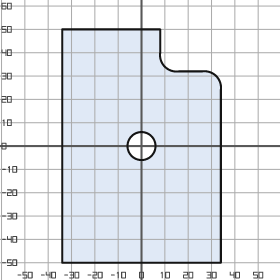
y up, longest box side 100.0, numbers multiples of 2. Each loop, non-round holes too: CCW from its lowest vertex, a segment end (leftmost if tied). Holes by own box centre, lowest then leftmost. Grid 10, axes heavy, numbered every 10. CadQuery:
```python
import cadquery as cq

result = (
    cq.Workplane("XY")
    .moveTo(-34.0, -50.0)
    .lineTo(34.0, -50.0)
    .lineTo(34.0, 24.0)
    .threePointArc((32.0, 30.0), (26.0, 32.0))
    .lineTo(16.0, 32.0)
    .threePointArc((10.0, 34.0), (8.0, 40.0))
    .lineTo(8.0, 50.0)
    .lineTo(-34.0, 50.0)
    .close()
    .moveTo(0.0, 0.0)
    .circle(6.0)
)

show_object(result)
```